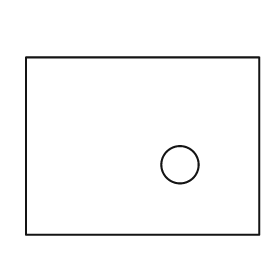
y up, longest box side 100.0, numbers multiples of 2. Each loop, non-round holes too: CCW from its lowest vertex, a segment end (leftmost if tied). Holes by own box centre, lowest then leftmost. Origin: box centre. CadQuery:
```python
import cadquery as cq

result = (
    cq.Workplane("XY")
    .moveTo(-50.0, -38.0)
    .lineTo(50.0, -38.0)
    .lineTo(50.0, 38.0)
    .lineTo(-50.0, 38.0)
    .close()
    .moveTo(16.0, -8.0)
    .circle(8.0)
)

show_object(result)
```